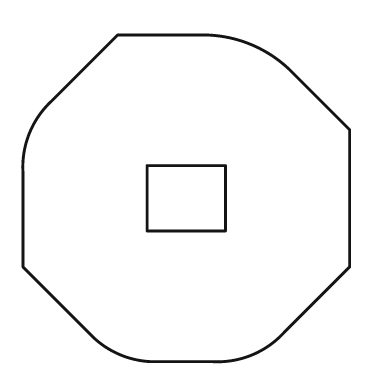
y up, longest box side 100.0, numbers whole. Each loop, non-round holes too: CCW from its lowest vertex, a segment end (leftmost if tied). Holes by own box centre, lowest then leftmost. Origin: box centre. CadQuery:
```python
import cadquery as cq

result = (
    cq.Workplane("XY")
    .moveTo(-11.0, -50.0)
    .lineTo(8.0, -50.0)
    .threePointArc((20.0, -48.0), (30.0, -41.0))
    .lineTo(50.0, -21.0)
    .lineTo(50.0, 21.0)
    .lineTo(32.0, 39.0)
    .threePointArc((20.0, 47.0), (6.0, 50.0))
    .lineTo(-21.0, 50.0)
    .lineTo(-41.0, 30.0)
    .threePointArc((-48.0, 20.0), (-50.0, 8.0))
    .lineTo(-50.0, -21.0)
    .lineTo(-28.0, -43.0)
    .threePointArc((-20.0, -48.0), (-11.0, -50.0))
    .close()
    .moveTo(-12.0, -10.0)
    .lineTo(12.0, -10.0)
    .lineTo(12.0, 10.0)
    .lineTo(-12.0, 10.0)
    .close()
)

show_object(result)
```